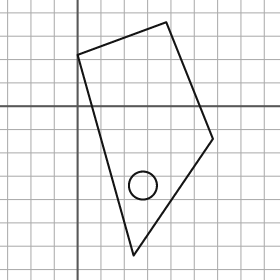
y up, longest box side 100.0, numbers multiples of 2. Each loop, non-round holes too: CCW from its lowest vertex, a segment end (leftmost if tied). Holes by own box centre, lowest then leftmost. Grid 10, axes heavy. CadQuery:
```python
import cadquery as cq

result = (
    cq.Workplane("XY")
    .moveTo(24.0, -64.0)
    .lineTo(58.0, -14.0)
    .lineTo(38.0, 36.0)
    .lineTo(0.0, 22.0)
    .close()
    .moveTo(28.0, -34.0)
    .circle(6.0)
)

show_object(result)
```